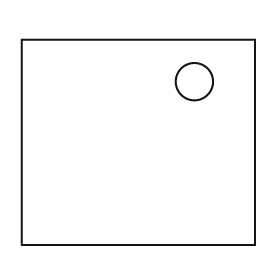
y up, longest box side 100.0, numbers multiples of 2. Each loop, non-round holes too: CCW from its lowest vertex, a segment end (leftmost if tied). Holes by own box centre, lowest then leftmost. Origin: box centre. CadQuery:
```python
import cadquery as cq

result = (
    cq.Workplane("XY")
    .moveTo(-50.0, -44.0)
    .lineTo(50.0, -44.0)
    .lineTo(50.0, 44.0)
    .lineTo(-50.0, 44.0)
    .close()
    .moveTo(24.0, 26.0)
    .circle(8.0)
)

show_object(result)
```